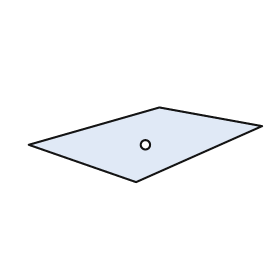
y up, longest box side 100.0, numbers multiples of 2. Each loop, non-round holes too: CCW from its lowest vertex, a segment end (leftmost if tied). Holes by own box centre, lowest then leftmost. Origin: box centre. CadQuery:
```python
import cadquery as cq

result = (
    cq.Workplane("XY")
    .moveTo(-4.0, -16.0)
    .lineTo(50.0, 8.0)
    .lineTo(6.0, 16.0)
    .lineTo(-50.0, 0.0)
    .close()
    .moveTo(0.0, 0.0)
    .circle(2.0)
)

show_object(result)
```